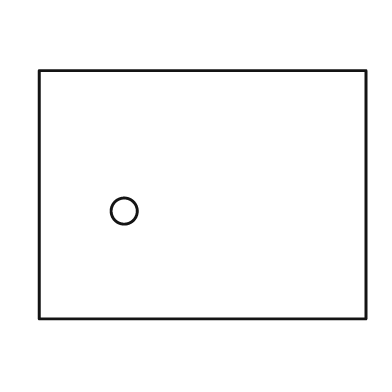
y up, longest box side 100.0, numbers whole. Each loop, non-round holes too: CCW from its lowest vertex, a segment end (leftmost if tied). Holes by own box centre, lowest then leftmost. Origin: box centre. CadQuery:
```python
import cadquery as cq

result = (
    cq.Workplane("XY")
    .moveTo(-50.0, -38.0)
    .lineTo(50.0, -38.0)
    .lineTo(50.0, 38.0)
    .lineTo(-50.0, 38.0)
    .close()
    .moveTo(-24.0, -5.0)
    .circle(4.0)
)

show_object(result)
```